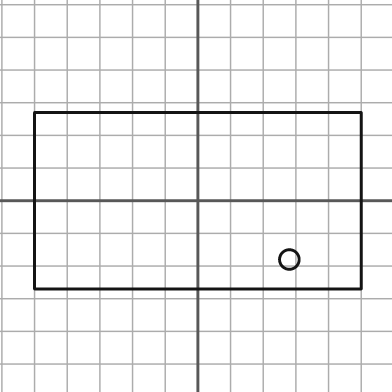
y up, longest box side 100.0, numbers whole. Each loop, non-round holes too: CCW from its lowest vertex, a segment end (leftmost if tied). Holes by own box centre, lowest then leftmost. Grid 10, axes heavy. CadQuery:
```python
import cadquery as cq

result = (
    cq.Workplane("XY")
    .moveTo(-50.0, -27.0)
    .lineTo(50.0, -27.0)
    .lineTo(50.0, 27.0)
    .lineTo(-50.0, 27.0)
    .close()
    .moveTo(28.0, -18.0)
    .circle(3.0)
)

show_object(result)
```